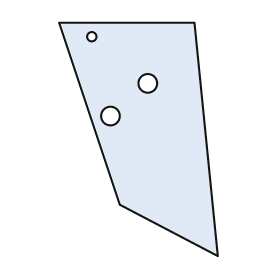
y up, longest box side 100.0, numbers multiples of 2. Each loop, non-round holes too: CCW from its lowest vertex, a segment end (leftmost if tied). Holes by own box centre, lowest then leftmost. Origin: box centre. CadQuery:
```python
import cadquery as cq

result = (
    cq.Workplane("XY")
    .moveTo(34.0, -50.0)
    .lineTo(24.0, 50.0)
    .lineTo(-34.0, 50.0)
    .lineTo(-8.0, -28.0)
    .close()
    .moveTo(-12.0, 10.0)
    .circle(4.0)
    .moveTo(4.0, 24.0)
    .circle(4.0)
    .moveTo(-20.0, 44.0)
    .circle(2.0)
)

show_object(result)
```